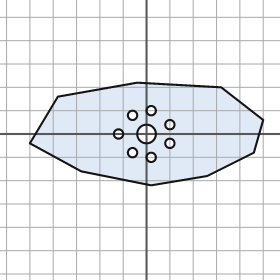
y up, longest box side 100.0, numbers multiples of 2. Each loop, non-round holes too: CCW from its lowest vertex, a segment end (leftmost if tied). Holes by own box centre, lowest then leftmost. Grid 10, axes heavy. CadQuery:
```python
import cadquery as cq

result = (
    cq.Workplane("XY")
    .moveTo(2.0, -22.0)
    .lineTo(26.0, -18.0)
    .lineTo(46.0, -8.0)
    .lineTo(50.0, 6.0)
    .lineTo(32.0, 20.0)
    .lineTo(-4.0, 22.0)
    .lineTo(-38.0, 16.0)
    .lineTo(-50.0, -4.0)
    .lineTo(-28.0, -16.0)
    .close()
    .moveTo(2.0, -10.0)
    .circle(2.0)
    .moveTo(-6.0, -8.0)
    .circle(2.0)
    .moveTo(10.0, -4.0)
    .circle(2.0)
    .moveTo(-12.0, 0.0)
    .circle(2.0)
    .moveTo(0.0, 0.0)
    .circle(4.0)
    .moveTo(10.0, 4.0)
    .circle(2.0)
    .moveTo(-6.0, 8.0)
    .circle(2.0)
    .moveTo(2.0, 10.0)
    .circle(2.0)
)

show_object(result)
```